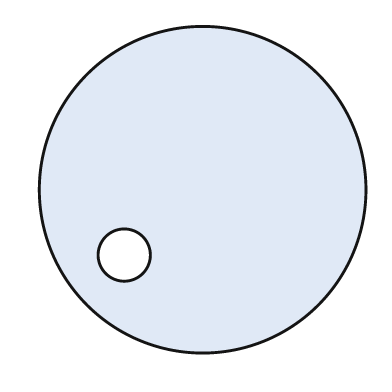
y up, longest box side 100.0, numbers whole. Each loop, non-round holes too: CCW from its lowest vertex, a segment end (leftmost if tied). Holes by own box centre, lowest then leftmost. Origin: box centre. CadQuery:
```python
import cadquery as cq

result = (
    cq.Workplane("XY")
    .moveTo(0.0, 0.0)
    .circle(50.0)
    .moveTo(-24.0, -20.0)
    .circle(8.0)
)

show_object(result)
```